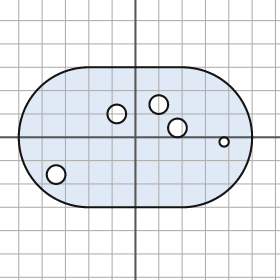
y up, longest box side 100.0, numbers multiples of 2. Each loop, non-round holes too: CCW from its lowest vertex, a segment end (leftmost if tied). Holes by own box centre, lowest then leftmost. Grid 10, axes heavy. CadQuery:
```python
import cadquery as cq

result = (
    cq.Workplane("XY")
    .moveTo(-20.0, -30.0)
    .lineTo(20.0, -30.0)
    .threePointArc((50.0, 0.0), (20.0, 30.0))
    .lineTo(-20.0, 30.0)
    .threePointArc((-50.0, 0.0), (-20.0, -30.0))
    .close()
    .moveTo(-34.0, -16.0)
    .circle(4.0)
    .moveTo(38.0, -2.0)
    .circle(2.0)
    .moveTo(18.0, 4.0)
    .circle(4.0)
    .moveTo(-8.0, 10.0)
    .circle(4.0)
    .moveTo(10.0, 14.0)
    .circle(4.0)
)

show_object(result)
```